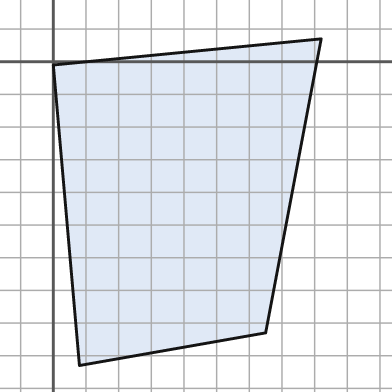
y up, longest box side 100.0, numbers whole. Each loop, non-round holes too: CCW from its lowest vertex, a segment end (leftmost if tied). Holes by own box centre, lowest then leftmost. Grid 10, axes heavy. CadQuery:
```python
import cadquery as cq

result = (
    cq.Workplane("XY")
    .moveTo(8.0, -93.0)
    .lineTo(65.0, -83.0)
    .lineTo(82.0, 7.0)
    .lineTo(0.0, -1.0)
    .close()
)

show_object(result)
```